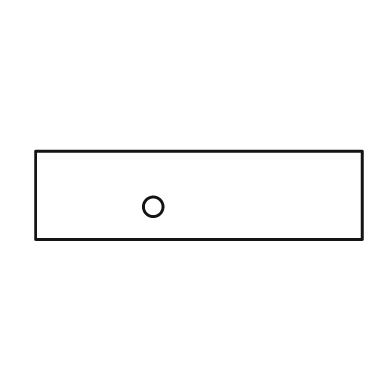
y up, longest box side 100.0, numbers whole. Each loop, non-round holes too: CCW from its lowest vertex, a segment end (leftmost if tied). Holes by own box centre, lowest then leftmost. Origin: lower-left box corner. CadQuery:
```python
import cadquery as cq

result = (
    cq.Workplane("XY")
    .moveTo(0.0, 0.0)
    .lineTo(100.0, 0.0)
    .lineTo(100.0, 27.0)
    .lineTo(0.0, 27.0)
    .close()
    .moveTo(36.0, 10.0)
    .circle(3.0)
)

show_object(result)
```